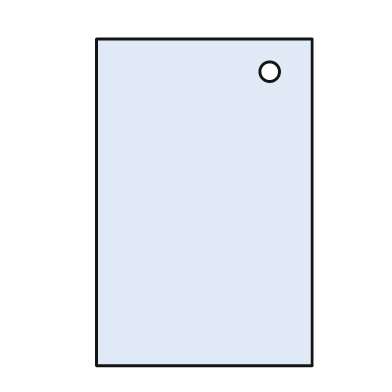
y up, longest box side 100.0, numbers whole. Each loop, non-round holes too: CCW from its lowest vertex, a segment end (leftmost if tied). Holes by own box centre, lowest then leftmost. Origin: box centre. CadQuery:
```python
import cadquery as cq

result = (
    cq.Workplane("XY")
    .moveTo(-33.0, -50.0)
    .lineTo(33.0, -50.0)
    .lineTo(33.0, 50.0)
    .lineTo(-33.0, 50.0)
    .close()
    .moveTo(20.0, 40.0)
    .circle(3.0)
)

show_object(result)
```